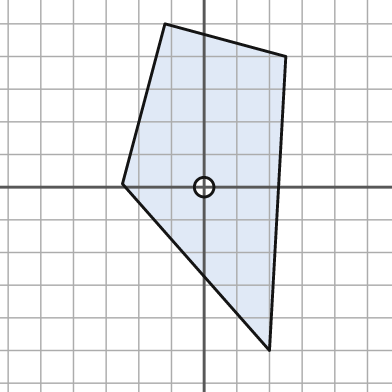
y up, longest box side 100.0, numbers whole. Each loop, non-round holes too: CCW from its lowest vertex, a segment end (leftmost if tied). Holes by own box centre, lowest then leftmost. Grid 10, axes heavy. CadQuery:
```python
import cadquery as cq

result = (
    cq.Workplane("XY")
    .moveTo(20.0, -50.0)
    .lineTo(25.0, 40.0)
    .lineTo(-12.0, 50.0)
    .lineTo(-25.0, 1.0)
    .close()
    .moveTo(0.0, 0.0)
    .circle(3.0)
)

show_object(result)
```